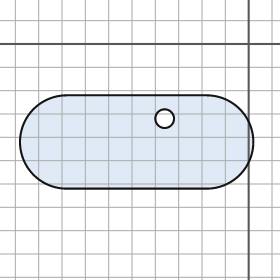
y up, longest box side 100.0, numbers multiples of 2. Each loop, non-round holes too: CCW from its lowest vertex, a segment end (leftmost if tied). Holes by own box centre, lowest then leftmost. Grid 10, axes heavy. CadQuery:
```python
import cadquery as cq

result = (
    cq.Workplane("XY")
    .moveTo(-78.0, -62.0)
    .lineTo(-18.0, -62.0)
    .threePointArc((2.0, -42.0), (-18.0, -22.0))
    .lineTo(-78.0, -22.0)
    .threePointArc((-98.0, -42.0), (-78.0, -62.0))
    .close()
    .moveTo(-36.0, -32.0)
    .circle(4.0)
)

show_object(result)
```